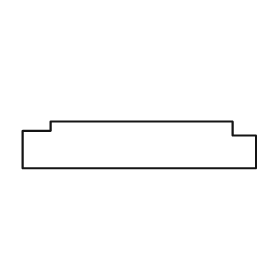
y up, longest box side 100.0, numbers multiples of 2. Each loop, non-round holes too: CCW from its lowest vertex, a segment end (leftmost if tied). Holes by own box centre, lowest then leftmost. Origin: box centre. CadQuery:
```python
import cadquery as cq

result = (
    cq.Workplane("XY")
    .moveTo(-50.0, -10.0)
    .lineTo(50.0, -10.0)
    .lineTo(50.0, 4.0)
    .lineTo(40.0, 4.0)
    .lineTo(40.0, 10.0)
    .lineTo(-38.0, 10.0)
    .lineTo(-38.0, 6.0)
    .lineTo(-50.0, 6.0)
    .close()
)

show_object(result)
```